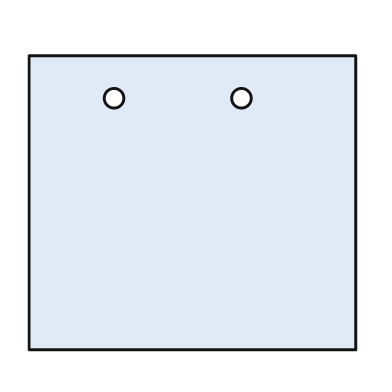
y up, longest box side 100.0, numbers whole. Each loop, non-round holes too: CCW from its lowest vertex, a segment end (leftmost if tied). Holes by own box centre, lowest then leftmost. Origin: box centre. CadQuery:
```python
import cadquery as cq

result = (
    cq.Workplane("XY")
    .moveTo(-50.0, -45.0)
    .lineTo(50.0, -45.0)
    .lineTo(50.0, 45.0)
    .lineTo(-50.0, 45.0)
    .close()
    .moveTo(-24.0, 32.0)
    .circle(3.0)
    .moveTo(15.0, 32.0)
    .circle(3.0)
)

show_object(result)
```